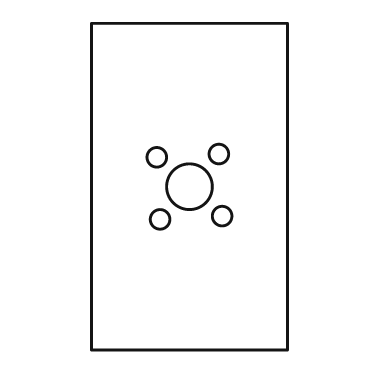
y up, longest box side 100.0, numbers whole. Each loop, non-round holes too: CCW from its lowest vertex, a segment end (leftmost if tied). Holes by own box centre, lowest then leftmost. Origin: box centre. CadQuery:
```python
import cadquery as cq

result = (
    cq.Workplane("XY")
    .moveTo(-30.0, -50.0)
    .lineTo(30.0, -50.0)
    .lineTo(30.0, 50.0)
    .lineTo(-30.0, 50.0)
    .close()
    .moveTo(-9.0, -10.0)
    .circle(3.0)
    .moveTo(10.0, -9.0)
    .circle(3.0)
    .moveTo(0.0, 0.0)
    .circle(7.0)
    .moveTo(-10.0, 9.0)
    .circle(3.0)
    .moveTo(9.0, 10.0)
    .circle(3.0)
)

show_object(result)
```